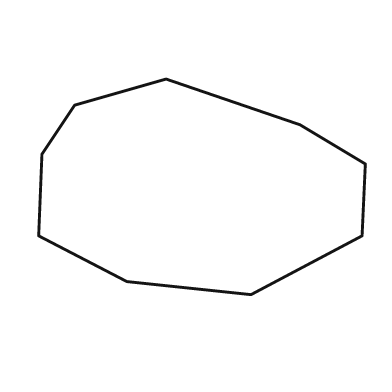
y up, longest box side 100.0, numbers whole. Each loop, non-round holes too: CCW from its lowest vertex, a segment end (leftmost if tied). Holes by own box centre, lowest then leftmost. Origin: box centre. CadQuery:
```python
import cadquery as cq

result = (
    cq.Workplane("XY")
    .moveTo(15.0, -33.0)
    .lineTo(49.0, -15.0)
    .lineTo(50.0, 7.0)
    .lineTo(30.0, 19.0)
    .lineTo(-11.0, 33.0)
    .lineTo(-39.0, 25.0)
    .lineTo(-49.0, 10.0)
    .lineTo(-50.0, -15.0)
    .lineTo(-23.0, -29.0)
    .close()
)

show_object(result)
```